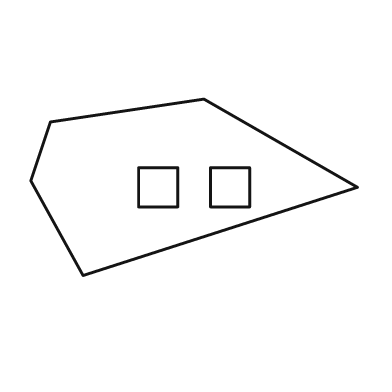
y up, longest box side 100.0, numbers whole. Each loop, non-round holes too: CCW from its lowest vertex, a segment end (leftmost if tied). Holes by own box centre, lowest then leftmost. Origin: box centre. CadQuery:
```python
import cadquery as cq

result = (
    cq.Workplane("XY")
    .moveTo(-34.0, -27.0)
    .lineTo(50.0, 0.0)
    .lineTo(3.0, 27.0)
    .lineTo(-44.0, 20.0)
    .lineTo(-50.0, 2.0)
    .close()
    .moveTo(-17.0, -6.0)
    .lineTo(-5.0, -6.0)
    .lineTo(-5.0, 6.0)
    .lineTo(-17.0, 6.0)
    .close()
    .moveTo(5.0, -6.0)
    .lineTo(17.0, -6.0)
    .lineTo(17.0, 6.0)
    .lineTo(5.0, 6.0)
    .close()
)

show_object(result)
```